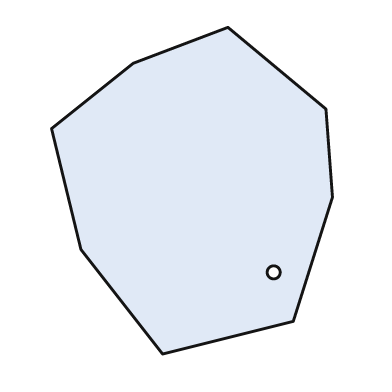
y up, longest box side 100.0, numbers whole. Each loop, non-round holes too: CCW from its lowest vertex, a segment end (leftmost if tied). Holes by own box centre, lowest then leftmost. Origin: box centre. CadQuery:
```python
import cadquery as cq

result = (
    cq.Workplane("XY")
    .moveTo(-9.0, -50.0)
    .lineTo(31.0, -40.0)
    .lineTo(43.0, -2.0)
    .lineTo(41.0, 25.0)
    .lineTo(11.0, 50.0)
    .lineTo(-18.0, 39.0)
    .lineTo(-43.0, 19.0)
    .lineTo(-34.0, -18.0)
    .close()
    .moveTo(25.0, -25.0)
    .circle(2.0)
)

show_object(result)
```